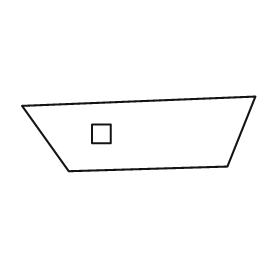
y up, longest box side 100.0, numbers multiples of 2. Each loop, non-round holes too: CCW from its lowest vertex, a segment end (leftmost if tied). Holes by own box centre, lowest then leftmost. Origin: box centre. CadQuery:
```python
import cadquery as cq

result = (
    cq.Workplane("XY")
    .moveTo(-30.0, -16.0)
    .lineTo(38.0, -14.0)
    .lineTo(50.0, 16.0)
    .lineTo(-50.0, 12.0)
    .close()
    .moveTo(-20.0, -4.0)
    .lineTo(-12.0, -4.0)
    .lineTo(-12.0, 4.0)
    .lineTo(-20.0, 4.0)
    .close()
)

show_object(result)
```